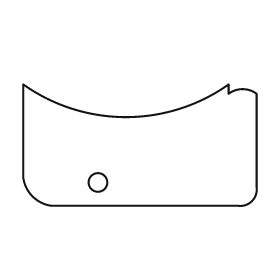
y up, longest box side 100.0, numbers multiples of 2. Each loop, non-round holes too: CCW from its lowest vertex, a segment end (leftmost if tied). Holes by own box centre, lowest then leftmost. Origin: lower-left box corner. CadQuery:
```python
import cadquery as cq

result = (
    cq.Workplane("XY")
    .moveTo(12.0, 0.0)
    .lineTo(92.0, 0.0)
    .threePointArc((98.0, 2.0), (100.0, 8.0))
    .lineTo(100.0, 48.0)
    .threePointArc((94.0, 50.0), (88.0, 48.0))
    .lineTo(88.0, 52.0)
    .threePointArc((44.0, 38.0), (0.0, 52.0))
    .lineTo(0.0, 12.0)
    .threePointArc((4.0, 4.0), (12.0, 0.0))
    .close()
    .moveTo(32.0, 10.0)
    .circle(4.0)
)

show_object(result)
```